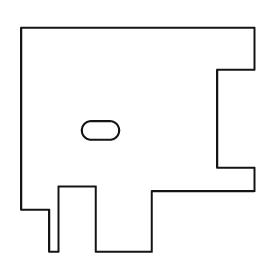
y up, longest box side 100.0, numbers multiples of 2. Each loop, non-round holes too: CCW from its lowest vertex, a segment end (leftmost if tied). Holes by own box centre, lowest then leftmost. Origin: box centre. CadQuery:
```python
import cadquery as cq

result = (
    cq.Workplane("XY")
    .moveTo(-38.0, -48.0)
    .lineTo(-34.0, -48.0)
    .lineTo(-34.0, -20.0)
    .lineTo(-18.0, -20.0)
    .lineTo(-18.0, -48.0)
    .lineTo(6.0, -48.0)
    .lineTo(6.0, -22.0)
    .lineTo(50.0, -22.0)
    .lineTo(50.0, -12.0)
    .lineTo(34.0, -12.0)
    .lineTo(34.0, 30.0)
    .lineTo(50.0, 30.0)
    .lineTo(50.0, 48.0)
    .lineTo(-50.0, 48.0)
    .lineTo(-50.0, -30.0)
    .lineTo(-38.0, -30.0)
    .close()
    .moveTo(-20.0, 0.0)
    .lineTo(-12.0, 0.0)
    .threePointArc((-8.0, 4.0), (-12.0, 8.0))
    .lineTo(-20.0, 8.0)
    .threePointArc((-24.0, 4.0), (-20.0, 0.0))
    .close()
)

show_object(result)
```